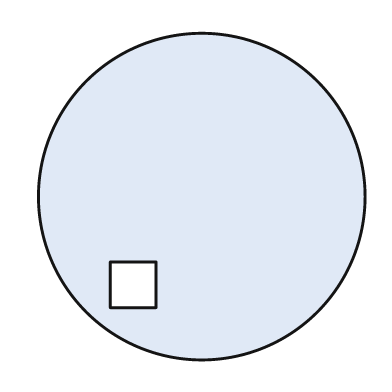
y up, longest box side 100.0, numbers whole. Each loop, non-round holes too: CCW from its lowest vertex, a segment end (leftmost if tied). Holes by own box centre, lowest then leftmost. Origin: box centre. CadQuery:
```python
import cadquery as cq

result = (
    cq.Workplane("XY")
    .moveTo(0.0, 0.0)
    .circle(50.0)
    .moveTo(-28.0, -34.0)
    .lineTo(-14.0, -34.0)
    .lineTo(-14.0, -20.0)
    .lineTo(-28.0, -20.0)
    .close()
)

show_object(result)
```